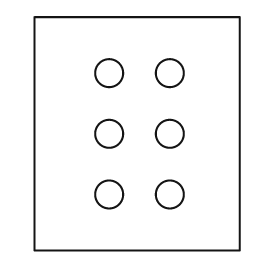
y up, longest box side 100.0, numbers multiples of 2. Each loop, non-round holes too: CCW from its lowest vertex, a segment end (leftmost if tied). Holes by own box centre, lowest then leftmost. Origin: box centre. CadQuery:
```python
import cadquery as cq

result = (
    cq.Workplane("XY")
    .moveTo(-44.0, -50.0)
    .lineTo(44.0, -50.0)
    .lineTo(44.0, 50.0)
    .lineTo(-44.0, 50.0)
    .close()
    .moveTo(-12.0, -26.0)
    .circle(6.0)
    .moveTo(14.0, -26.0)
    .circle(6.0)
    .moveTo(-12.0, 0.0)
    .circle(6.0)
    .moveTo(14.0, 0.0)
    .circle(6.0)
    .moveTo(-12.0, 26.0)
    .circle(6.0)
    .moveTo(14.0, 26.0)
    .circle(6.0)
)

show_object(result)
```